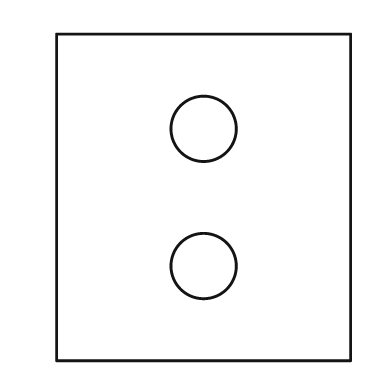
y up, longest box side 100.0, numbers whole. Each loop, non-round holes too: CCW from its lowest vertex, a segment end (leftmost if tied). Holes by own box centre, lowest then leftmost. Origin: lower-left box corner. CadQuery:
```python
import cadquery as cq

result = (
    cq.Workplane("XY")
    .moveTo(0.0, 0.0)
    .lineTo(90.0, 0.0)
    .lineTo(90.0, 100.0)
    .lineTo(0.0, 100.0)
    .close()
    .moveTo(45.0, 29.0)
    .circle(10.0)
    .moveTo(45.0, 71.0)
    .circle(10.0)
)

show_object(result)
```